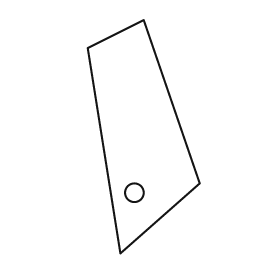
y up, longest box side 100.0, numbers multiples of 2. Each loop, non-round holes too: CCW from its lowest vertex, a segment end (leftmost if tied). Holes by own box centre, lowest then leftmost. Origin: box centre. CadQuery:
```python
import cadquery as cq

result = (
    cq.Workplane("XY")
    .moveTo(-10.0, -50.0)
    .lineTo(24.0, -20.0)
    .lineTo(0.0, 50.0)
    .lineTo(-24.0, 38.0)
    .close()
    .moveTo(-4.0, -24.0)
    .circle(4.0)
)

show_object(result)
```